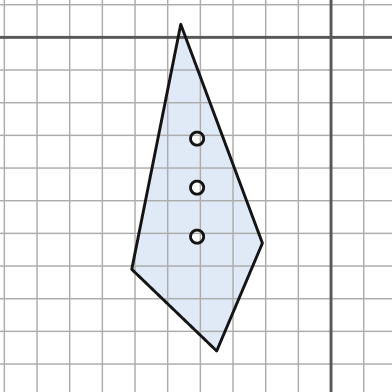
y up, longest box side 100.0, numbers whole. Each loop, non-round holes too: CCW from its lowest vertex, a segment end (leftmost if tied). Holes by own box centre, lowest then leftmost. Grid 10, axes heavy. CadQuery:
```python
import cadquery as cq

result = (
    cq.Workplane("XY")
    .moveTo(-35.0, -96.0)
    .lineTo(-21.0, -63.0)
    .lineTo(-46.0, 4.0)
    .lineTo(-61.0, -71.0)
    .close()
    .moveTo(-41.0, -61.0)
    .circle(2.0)
    .moveTo(-41.0, -46.0)
    .circle(2.0)
    .moveTo(-41.0, -31.0)
    .circle(2.0)
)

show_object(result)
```